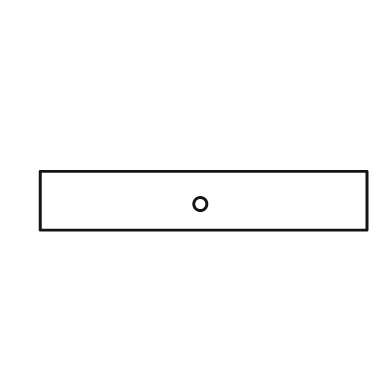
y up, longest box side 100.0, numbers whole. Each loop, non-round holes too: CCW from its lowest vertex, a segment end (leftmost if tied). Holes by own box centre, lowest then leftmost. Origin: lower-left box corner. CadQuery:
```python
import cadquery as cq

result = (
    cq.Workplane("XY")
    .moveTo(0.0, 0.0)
    .lineTo(100.0, 0.0)
    .lineTo(100.0, 18.0)
    .lineTo(0.0, 18.0)
    .close()
    .moveTo(49.0, 8.0)
    .circle(2.0)
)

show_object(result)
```